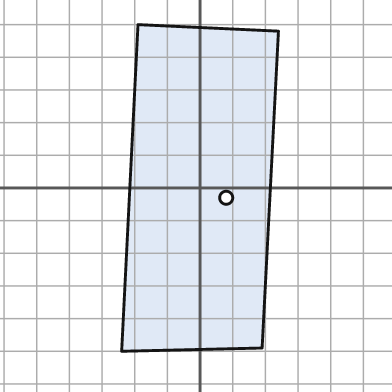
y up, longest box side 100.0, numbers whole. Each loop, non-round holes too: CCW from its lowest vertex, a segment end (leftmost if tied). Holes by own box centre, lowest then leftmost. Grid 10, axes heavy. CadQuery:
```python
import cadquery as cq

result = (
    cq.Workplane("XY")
    .moveTo(-24.0, -50.0)
    .lineTo(19.0, -49.0)
    .lineTo(24.0, 48.0)
    .lineTo(-19.0, 50.0)
    .close()
    .moveTo(8.0, -3.0)
    .circle(2.0)
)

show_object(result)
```